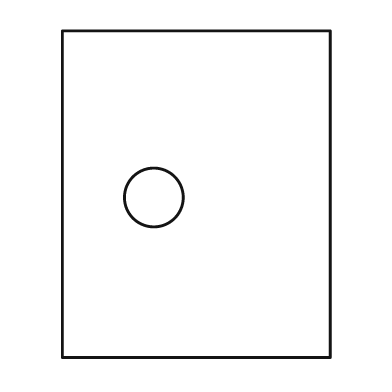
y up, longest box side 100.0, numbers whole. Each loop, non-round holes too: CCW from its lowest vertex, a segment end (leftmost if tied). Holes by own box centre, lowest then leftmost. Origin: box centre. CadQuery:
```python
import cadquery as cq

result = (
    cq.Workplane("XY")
    .moveTo(-41.0, -50.0)
    .lineTo(41.0, -50.0)
    .lineTo(41.0, 50.0)
    .lineTo(-41.0, 50.0)
    .close()
    .moveTo(-13.0, -1.0)
    .circle(9.0)
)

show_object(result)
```